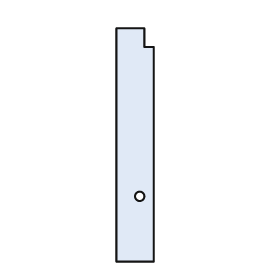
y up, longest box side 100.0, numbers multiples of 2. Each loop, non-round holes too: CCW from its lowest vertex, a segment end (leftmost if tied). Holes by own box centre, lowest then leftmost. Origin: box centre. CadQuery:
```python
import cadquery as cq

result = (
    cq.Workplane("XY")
    .moveTo(-8.0, -50.0)
    .lineTo(8.0, -50.0)
    .lineTo(8.0, 42.0)
    .lineTo(4.0, 42.0)
    .lineTo(4.0, 50.0)
    .lineTo(-8.0, 50.0)
    .close()
    .moveTo(2.0, -22.0)
    .circle(2.0)
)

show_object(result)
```